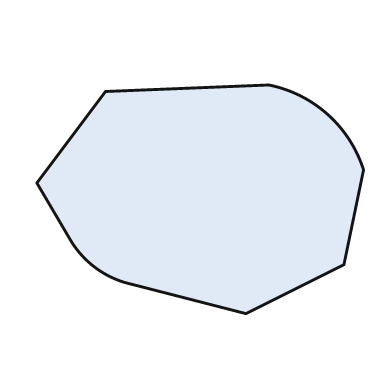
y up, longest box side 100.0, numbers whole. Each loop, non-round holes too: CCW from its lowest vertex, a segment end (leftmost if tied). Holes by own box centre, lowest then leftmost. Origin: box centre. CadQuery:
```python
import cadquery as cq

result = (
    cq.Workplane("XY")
    .moveTo(14.0, -35.0)
    .lineTo(44.0, -20.0)
    .lineTo(50.0, 9.0)
    .threePointArc((39.0, 26.0), (21.0, 35.0))
    .lineTo(-29.0, 33.0)
    .lineTo(-50.0, 5.0)
    .lineTo(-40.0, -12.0)
    .threePointArc((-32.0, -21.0), (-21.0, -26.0))
    .close()
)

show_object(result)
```